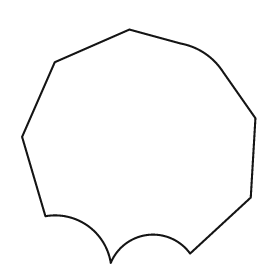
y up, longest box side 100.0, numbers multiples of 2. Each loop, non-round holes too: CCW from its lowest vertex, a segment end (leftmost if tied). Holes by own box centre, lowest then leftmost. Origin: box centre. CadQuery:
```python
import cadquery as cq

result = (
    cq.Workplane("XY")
    .moveTo(-12.0, -50.0)
    .threePointArc((4.0, -38.0), (22.0, -46.0))
    .lineTo(48.0, -22.0)
    .lineTo(50.0, 12.0)
    .lineTo(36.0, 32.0)
    .threePointArc((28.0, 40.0), (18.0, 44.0))
    .lineTo(-4.0, 50.0)
    .lineTo(-36.0, 36.0)
    .lineTo(-50.0, 4.0)
    .lineTo(-40.0, -30.0)
    .threePointArc((-22.0, -34.0), (-12.0, -50.0))
    .close()
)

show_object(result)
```